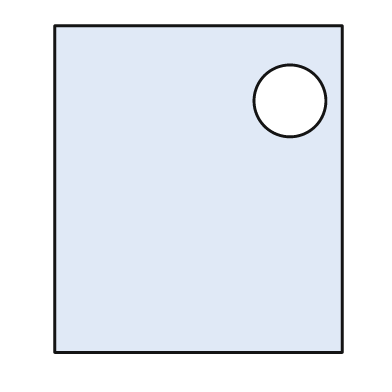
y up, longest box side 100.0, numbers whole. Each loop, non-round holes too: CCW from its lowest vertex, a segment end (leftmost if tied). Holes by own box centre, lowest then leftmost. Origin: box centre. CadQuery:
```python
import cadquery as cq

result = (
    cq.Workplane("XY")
    .moveTo(-44.0, -50.0)
    .lineTo(44.0, -50.0)
    .lineTo(44.0, 50.0)
    .lineTo(-44.0, 50.0)
    .close()
    .moveTo(28.0, 27.0)
    .circle(11.0)
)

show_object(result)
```